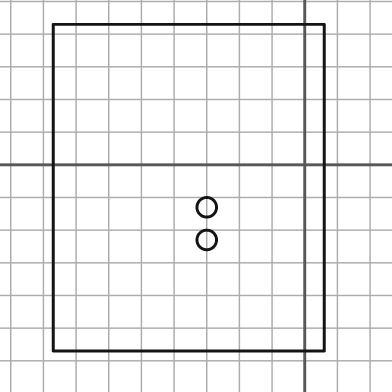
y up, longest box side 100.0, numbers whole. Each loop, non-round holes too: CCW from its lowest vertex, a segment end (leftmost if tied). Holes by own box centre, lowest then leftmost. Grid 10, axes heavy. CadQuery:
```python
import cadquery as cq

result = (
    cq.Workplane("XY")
    .moveTo(-77.0, -57.0)
    .lineTo(6.0, -57.0)
    .lineTo(6.0, 43.0)
    .lineTo(-77.0, 43.0)
    .close()
    .moveTo(-30.0, -23.0)
    .circle(3.0)
    .moveTo(-30.0, -13.0)
    .circle(3.0)
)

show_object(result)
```